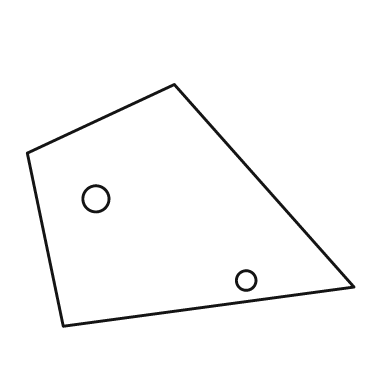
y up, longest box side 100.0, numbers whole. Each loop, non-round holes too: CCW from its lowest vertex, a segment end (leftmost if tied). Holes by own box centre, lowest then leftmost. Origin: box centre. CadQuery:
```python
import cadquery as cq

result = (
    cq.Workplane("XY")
    .moveTo(-39.0, -37.0)
    .lineTo(50.0, -25.0)
    .lineTo(-5.0, 37.0)
    .lineTo(-50.0, 16.0)
    .close()
    .moveTo(17.0, -23.0)
    .circle(3.0)
    .moveTo(-29.0, 2.0)
    .circle(4.0)
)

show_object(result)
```